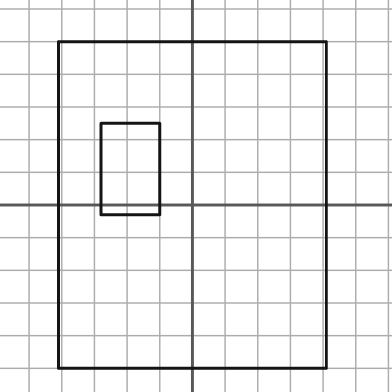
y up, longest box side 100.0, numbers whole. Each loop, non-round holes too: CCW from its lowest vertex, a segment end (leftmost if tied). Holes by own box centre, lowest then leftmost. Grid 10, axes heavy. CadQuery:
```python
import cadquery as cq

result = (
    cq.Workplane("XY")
    .moveTo(-41.0, -50.0)
    .lineTo(41.0, -50.0)
    .lineTo(41.0, 50.0)
    .lineTo(-41.0, 50.0)
    .close()
    .moveTo(-28.0, -3.0)
    .lineTo(-10.0, -3.0)
    .lineTo(-10.0, 25.0)
    .lineTo(-28.0, 25.0)
    .close()
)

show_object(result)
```